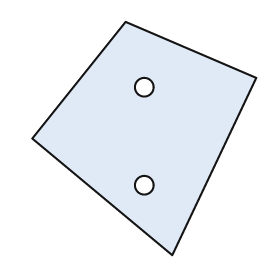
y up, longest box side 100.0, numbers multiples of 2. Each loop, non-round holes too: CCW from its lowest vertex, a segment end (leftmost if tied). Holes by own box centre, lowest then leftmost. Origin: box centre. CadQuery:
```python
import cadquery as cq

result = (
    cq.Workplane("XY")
    .moveTo(12.0, -50.0)
    .lineTo(48.0, 26.0)
    .lineTo(-8.0, 50.0)
    .lineTo(-48.0, 0.0)
    .close()
    .moveTo(0.0, -20.0)
    .circle(4.0)
    .moveTo(0.0, 22.0)
    .circle(4.0)
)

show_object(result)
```